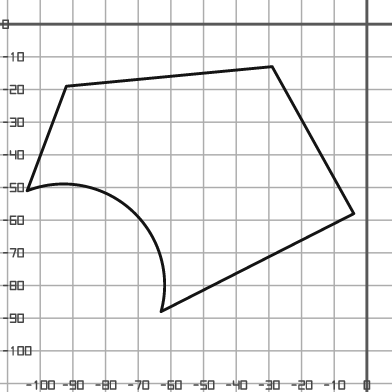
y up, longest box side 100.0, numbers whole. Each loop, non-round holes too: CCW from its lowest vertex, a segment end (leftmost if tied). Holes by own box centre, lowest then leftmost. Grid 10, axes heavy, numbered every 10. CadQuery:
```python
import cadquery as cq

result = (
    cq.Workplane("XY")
    .moveTo(-63.0, -88.0)
    .lineTo(-4.0, -58.0)
    .lineTo(-29.0, -13.0)
    .lineTo(-92.0, -19.0)
    .lineTo(-104.0, -51.0)
    .threePointArc((-72.0, -57.0), (-63.0, -88.0))
    .close()
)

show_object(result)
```